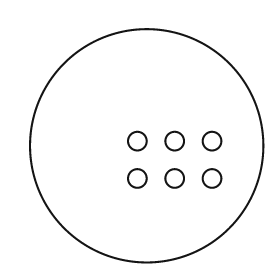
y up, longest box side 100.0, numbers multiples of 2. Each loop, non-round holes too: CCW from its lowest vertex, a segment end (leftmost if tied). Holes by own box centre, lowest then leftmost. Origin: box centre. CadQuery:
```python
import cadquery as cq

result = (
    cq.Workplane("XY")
    .moveTo(0.0, 0.0)
    .circle(50.0)
    .moveTo(-4.0, -14.0)
    .circle(4.0)
    .moveTo(12.0, -14.0)
    .circle(4.0)
    .moveTo(28.0, -14.0)
    .circle(4.0)
    .moveTo(-4.0, 2.0)
    .circle(4.0)
    .moveTo(12.0, 2.0)
    .circle(4.0)
    .moveTo(28.0, 2.0)
    .circle(4.0)
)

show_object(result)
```